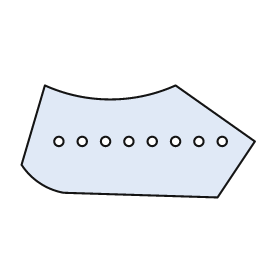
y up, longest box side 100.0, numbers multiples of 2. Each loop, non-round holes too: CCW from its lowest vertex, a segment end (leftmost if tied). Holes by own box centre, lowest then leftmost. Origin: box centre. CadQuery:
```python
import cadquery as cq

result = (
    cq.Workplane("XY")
    .moveTo(34.0, -24.0)
    .lineTo(50.0, 0.0)
    .lineTo(16.0, 24.0)
    .threePointArc((-12.0, 18.0), (-40.0, 24.0))
    .lineTo(-50.0, -10.0)
    .threePointArc((-42.0, -18.0), (-32.0, -22.0))
    .close()
    .moveTo(-34.0, 0.0)
    .circle(2.0)
    .moveTo(-24.0, 0.0)
    .circle(2.0)
    .moveTo(-14.0, 0.0)
    .circle(2.0)
    .moveTo(-4.0, 0.0)
    .circle(2.0)
    .moveTo(6.0, 0.0)
    .circle(2.0)
    .moveTo(16.0, 0.0)
    .circle(2.0)
    .moveTo(26.0, 0.0)
    .circle(2.0)
    .moveTo(36.0, 0.0)
    .circle(2.0)
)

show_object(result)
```